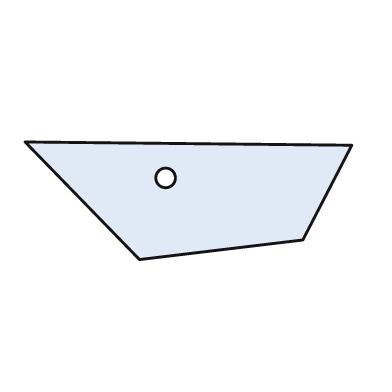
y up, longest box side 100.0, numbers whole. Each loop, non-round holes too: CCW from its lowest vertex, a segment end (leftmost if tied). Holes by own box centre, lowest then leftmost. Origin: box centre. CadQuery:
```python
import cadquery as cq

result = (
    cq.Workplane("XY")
    .moveTo(-15.0, -18.0)
    .lineTo(35.0, -12.0)
    .lineTo(50.0, 17.0)
    .lineTo(-50.0, 18.0)
    .close()
    .moveTo(-7.0, 7.0)
    .circle(3.0)
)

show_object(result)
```